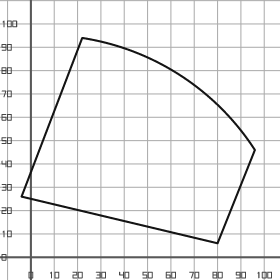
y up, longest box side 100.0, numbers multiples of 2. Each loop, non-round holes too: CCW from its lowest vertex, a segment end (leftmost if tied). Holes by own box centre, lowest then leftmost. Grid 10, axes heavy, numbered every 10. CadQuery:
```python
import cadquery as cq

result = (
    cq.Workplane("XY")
    .moveTo(80.0, 6.0)
    .lineTo(96.0, 46.0)
    .threePointArc((64.0, 78.0), (22.0, 94.0))
    .lineTo(-4.0, 26.0)
    .close()
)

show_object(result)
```